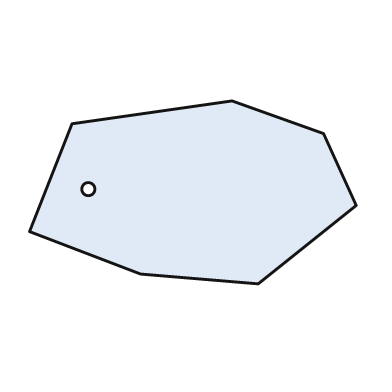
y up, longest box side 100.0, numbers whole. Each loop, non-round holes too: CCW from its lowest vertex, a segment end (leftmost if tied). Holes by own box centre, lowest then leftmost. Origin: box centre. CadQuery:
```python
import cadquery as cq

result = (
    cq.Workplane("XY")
    .moveTo(20.0, -28.0)
    .lineTo(50.0, -4.0)
    .lineTo(40.0, 18.0)
    .lineTo(12.0, 28.0)
    .lineTo(-37.0, 21.0)
    .lineTo(-50.0, -12.0)
    .lineTo(-16.0, -25.0)
    .close()
    .moveTo(-32.0, 1.0)
    .circle(2.0)
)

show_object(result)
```